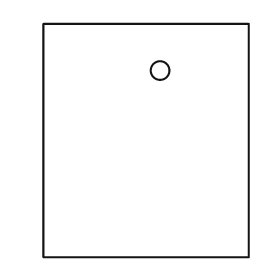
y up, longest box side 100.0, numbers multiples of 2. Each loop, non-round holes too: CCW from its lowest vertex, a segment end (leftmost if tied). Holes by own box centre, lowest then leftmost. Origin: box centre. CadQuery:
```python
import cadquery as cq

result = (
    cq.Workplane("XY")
    .moveTo(-44.0, -50.0)
    .lineTo(44.0, -50.0)
    .lineTo(44.0, 50.0)
    .lineTo(-44.0, 50.0)
    .close()
    .moveTo(6.0, 30.0)
    .circle(4.0)
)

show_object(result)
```